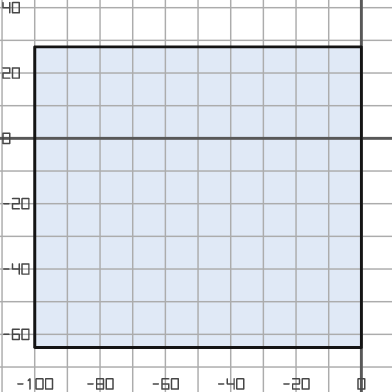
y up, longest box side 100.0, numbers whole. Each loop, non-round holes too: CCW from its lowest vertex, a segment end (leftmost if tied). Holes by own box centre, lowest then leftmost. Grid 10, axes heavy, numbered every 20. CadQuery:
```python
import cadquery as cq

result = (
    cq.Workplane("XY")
    .moveTo(-100.0, -64.0)
    .lineTo(0.0, -64.0)
    .lineTo(0.0, 28.0)
    .lineTo(-100.0, 28.0)
    .close()
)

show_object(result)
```